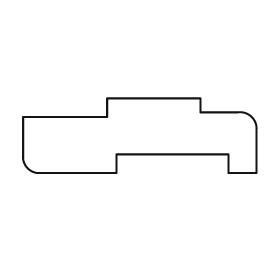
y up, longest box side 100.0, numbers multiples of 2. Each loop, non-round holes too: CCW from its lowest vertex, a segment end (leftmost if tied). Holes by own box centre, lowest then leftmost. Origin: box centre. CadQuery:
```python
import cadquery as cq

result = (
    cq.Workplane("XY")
    .moveTo(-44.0, -16.0)
    .lineTo(-10.0, -16.0)
    .lineTo(-10.0, -8.0)
    .lineTo(38.0, -8.0)
    .lineTo(38.0, -16.0)
    .lineTo(50.0, -16.0)
    .lineTo(50.0, 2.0)
    .threePointArc((48.0, 8.0), (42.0, 10.0))
    .lineTo(26.0, 10.0)
    .lineTo(26.0, 16.0)
    .lineTo(-14.0, 16.0)
    .lineTo(-14.0, 8.0)
    .lineTo(-50.0, 8.0)
    .lineTo(-50.0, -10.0)
    .threePointArc((-48.0, -14.0), (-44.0, -16.0))
    .close()
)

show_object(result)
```